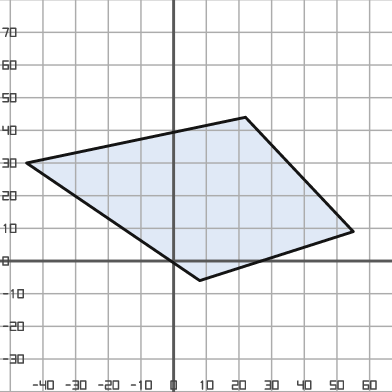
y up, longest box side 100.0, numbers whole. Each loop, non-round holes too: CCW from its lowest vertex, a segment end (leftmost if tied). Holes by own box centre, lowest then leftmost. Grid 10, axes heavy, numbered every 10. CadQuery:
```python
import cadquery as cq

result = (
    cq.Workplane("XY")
    .moveTo(8.0, -6.0)
    .lineTo(55.0, 9.0)
    .lineTo(22.0, 44.0)
    .lineTo(-45.0, 30.0)
    .close()
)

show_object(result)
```